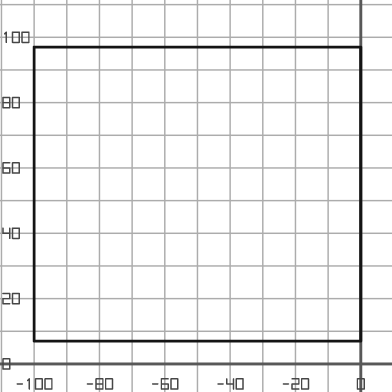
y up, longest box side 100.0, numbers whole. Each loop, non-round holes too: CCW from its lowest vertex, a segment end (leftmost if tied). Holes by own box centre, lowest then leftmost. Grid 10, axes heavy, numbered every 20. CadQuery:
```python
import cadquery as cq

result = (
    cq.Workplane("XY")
    .moveTo(-100.0, 7.0)
    .lineTo(0.0, 7.0)
    .lineTo(0.0, 97.0)
    .lineTo(-100.0, 97.0)
    .close()
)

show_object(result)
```